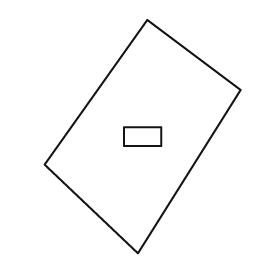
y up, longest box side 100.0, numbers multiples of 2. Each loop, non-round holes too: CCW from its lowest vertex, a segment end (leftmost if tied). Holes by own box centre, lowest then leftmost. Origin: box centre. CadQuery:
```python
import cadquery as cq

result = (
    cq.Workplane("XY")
    .moveTo(-2.0, -50.0)
    .lineTo(42.0, 20.0)
    .lineTo(2.0, 50.0)
    .lineTo(-42.0, -12.0)
    .close()
    .moveTo(-8.0, -4.0)
    .lineTo(8.0, -4.0)
    .lineTo(8.0, 4.0)
    .lineTo(-8.0, 4.0)
    .close()
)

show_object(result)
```